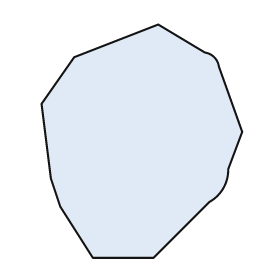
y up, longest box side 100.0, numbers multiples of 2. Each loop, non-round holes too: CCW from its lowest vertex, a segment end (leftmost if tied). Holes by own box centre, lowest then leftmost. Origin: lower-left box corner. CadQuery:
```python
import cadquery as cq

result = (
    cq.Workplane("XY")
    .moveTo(22.0, 0.0)
    .lineTo(48.0, 0.0)
    .lineTo(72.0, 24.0)
    .threePointArc((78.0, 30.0), (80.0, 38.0))
    .lineTo(86.0, 54.0)
    .lineTo(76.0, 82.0)
    .threePointArc((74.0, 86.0), (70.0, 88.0))
    .lineTo(50.0, 100.0)
    .lineTo(14.0, 86.0)
    .lineTo(0.0, 66.0)
    .lineTo(4.0, 34.0)
    .lineTo(8.0, 22.0)
    .close()
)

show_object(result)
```